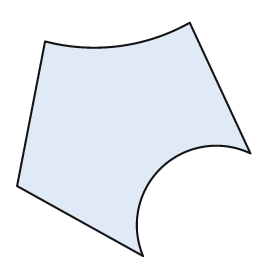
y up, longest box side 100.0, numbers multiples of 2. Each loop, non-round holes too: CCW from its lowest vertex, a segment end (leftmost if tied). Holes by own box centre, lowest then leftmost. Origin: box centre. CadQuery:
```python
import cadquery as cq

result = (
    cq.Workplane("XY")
    .moveTo(4.0, -50.0)
    .threePointArc((12.0, -12.0), (50.0, -6.0))
    .lineTo(24.0, 50.0)
    .threePointArc((-6.0, 40.0), (-38.0, 42.0))
    .lineTo(-50.0, -20.0)
    .close()
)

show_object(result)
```